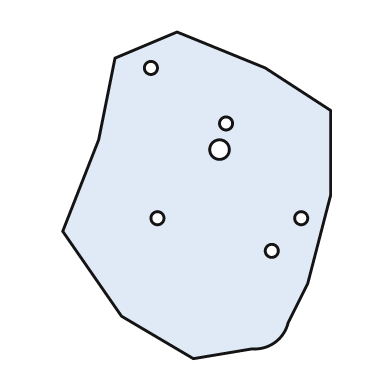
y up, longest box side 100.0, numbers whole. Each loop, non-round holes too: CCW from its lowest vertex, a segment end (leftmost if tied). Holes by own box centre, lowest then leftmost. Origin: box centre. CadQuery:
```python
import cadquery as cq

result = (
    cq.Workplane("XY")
    .moveTo(-1.0, -50.0)
    .lineTo(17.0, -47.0)
    .threePointArc((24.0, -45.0), (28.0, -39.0))
    .lineTo(34.0, -27.0)
    .lineTo(41.0, 0.0)
    .lineTo(41.0, 26.0)
    .lineTo(21.0, 39.0)
    .lineTo(-6.0, 50.0)
    .lineTo(-25.0, 42.0)
    .lineTo(-30.0, 17.0)
    .lineTo(-41.0, -11.0)
    .lineTo(-23.0, -37.0)
    .close()
    .moveTo(23.0, -17.0)
    .circle(2.0)
    .moveTo(-12.0, -7.0)
    .circle(2.0)
    .moveTo(32.0, -7.0)
    .circle(2.0)
    .moveTo(7.0, 14.0)
    .circle(3.0)
    .moveTo(9.0, 22.0)
    .circle(2.0)
    .moveTo(-14.0, 39.0)
    .circle(2.0)
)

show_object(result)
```